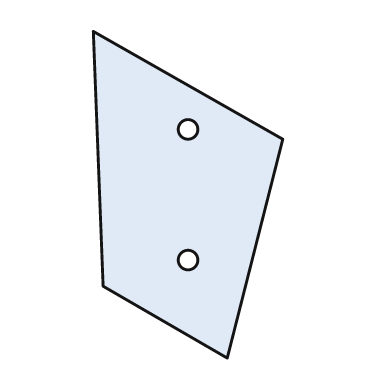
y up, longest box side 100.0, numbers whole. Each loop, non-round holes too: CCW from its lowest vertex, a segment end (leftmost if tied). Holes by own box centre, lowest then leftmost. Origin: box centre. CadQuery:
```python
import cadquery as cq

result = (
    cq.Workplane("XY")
    .moveTo(12.0, -50.0)
    .lineTo(29.0, 17.0)
    .lineTo(-29.0, 50.0)
    .lineTo(-26.0, -28.0)
    .close()
    .moveTo(0.0, -20.0)
    .circle(3.0)
    .moveTo(0.0, 20.0)
    .circle(3.0)
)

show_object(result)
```